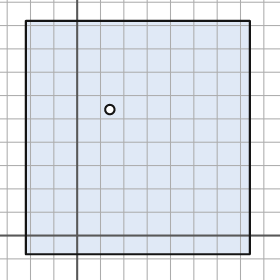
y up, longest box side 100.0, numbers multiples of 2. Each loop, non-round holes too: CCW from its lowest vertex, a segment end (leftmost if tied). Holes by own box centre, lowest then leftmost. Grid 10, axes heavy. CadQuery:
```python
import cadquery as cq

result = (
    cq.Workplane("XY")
    .moveTo(-22.0, -8.0)
    .lineTo(74.0, -8.0)
    .lineTo(74.0, 92.0)
    .lineTo(-22.0, 92.0)
    .close()
    .moveTo(14.0, 54.0)
    .circle(2.0)
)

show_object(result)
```